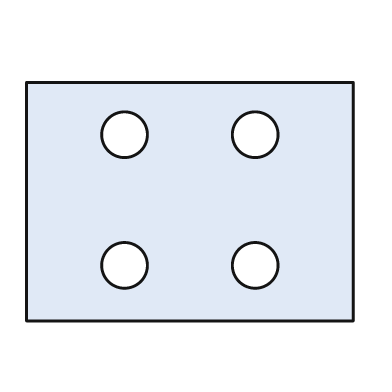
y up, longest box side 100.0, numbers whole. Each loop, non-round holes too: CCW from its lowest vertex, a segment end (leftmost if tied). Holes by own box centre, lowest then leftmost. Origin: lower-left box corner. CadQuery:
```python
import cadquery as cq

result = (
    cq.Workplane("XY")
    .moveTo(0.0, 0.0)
    .lineTo(100.0, 0.0)
    .lineTo(100.0, 73.0)
    .lineTo(0.0, 73.0)
    .close()
    .moveTo(30.0, 17.0)
    .circle(7.0)
    .moveTo(70.0, 17.0)
    .circle(7.0)
    .moveTo(30.0, 57.0)
    .circle(7.0)
    .moveTo(70.0, 57.0)
    .circle(7.0)
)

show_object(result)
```